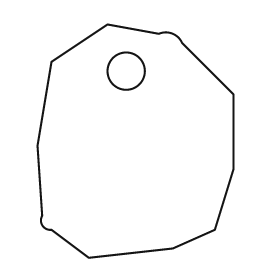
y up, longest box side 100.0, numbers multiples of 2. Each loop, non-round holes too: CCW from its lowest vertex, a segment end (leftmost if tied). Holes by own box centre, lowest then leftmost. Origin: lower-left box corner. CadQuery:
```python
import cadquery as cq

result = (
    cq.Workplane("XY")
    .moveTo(22.0, 0.0)
    .lineTo(58.0, 4.0)
    .lineTo(76.0, 12.0)
    .lineTo(84.0, 38.0)
    .lineTo(84.0, 70.0)
    .lineTo(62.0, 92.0)
    .threePointArc((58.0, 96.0), (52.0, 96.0))
    .lineTo(30.0, 100.0)
    .lineTo(6.0, 84.0)
    .lineTo(0.0, 48.0)
    .lineTo(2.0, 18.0)
    .threePointArc((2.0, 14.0), (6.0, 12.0))
    .close()
    .moveTo(38.0, 80.0)
    .circle(8.0)
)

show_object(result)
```